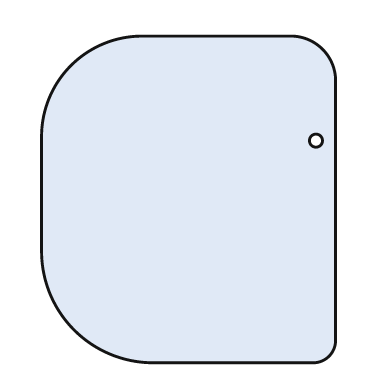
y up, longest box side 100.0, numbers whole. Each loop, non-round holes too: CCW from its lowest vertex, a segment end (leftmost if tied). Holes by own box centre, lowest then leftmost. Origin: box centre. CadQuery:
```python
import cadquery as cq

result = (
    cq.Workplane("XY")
    .moveTo(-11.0, -50.0)
    .lineTo(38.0, -50.0)
    .threePointArc((43.0, -48.0), (45.0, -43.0))
    .lineTo(45.0, 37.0)
    .threePointArc((41.0, 46.0), (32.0, 50.0))
    .lineTo(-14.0, 50.0)
    .threePointArc((-36.0, 41.0), (-45.0, 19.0))
    .lineTo(-45.0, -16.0)
    .threePointArc((-35.0, -40.0), (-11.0, -50.0))
    .close()
    .moveTo(39.0, 18.0)
    .circle(2.0)
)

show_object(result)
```